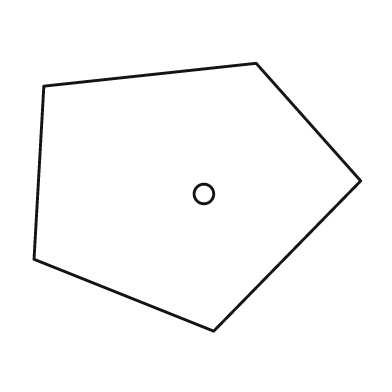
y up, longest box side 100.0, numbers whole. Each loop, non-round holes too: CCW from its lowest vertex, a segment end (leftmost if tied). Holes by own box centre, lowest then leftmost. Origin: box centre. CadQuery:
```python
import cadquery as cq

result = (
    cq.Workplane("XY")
    .moveTo(5.0, -41.0)
    .lineTo(50.0, 5.0)
    .lineTo(18.0, 41.0)
    .lineTo(-47.0, 34.0)
    .lineTo(-50.0, -19.0)
    .close()
    .moveTo(2.0, 1.0)
    .circle(3.0)
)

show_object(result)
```